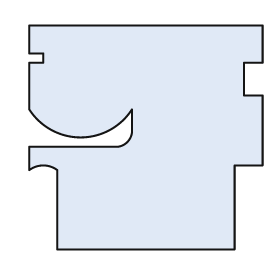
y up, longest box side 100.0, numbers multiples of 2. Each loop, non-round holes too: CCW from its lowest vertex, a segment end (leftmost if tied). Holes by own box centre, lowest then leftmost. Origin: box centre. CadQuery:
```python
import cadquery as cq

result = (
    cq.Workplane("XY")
    .moveTo(-38.0, -48.0)
    .lineTo(38.0, -48.0)
    .lineTo(38.0, -12.0)
    .lineTo(50.0, -12.0)
    .lineTo(50.0, 18.0)
    .lineTo(42.0, 18.0)
    .lineTo(42.0, 32.0)
    .lineTo(50.0, 32.0)
    .lineTo(50.0, 48.0)
    .lineTo(-50.0, 48.0)
    .lineTo(-50.0, 36.0)
    .lineTo(-44.0, 36.0)
    .lineTo(-44.0, 32.0)
    .lineTo(-50.0, 32.0)
    .lineTo(-50.0, 12.0)
    .threePointArc((-28.0, 0.0), (-6.0, 12.0))
    .lineTo(-6.0, 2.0)
    .threePointArc((-8.0, -2.0), (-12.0, -4.0))
    .lineTo(-50.0, -4.0)
    .lineTo(-50.0, -14.0)
    .threePointArc((-44.0, -12.0), (-38.0, -14.0))
    .close()
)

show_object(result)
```